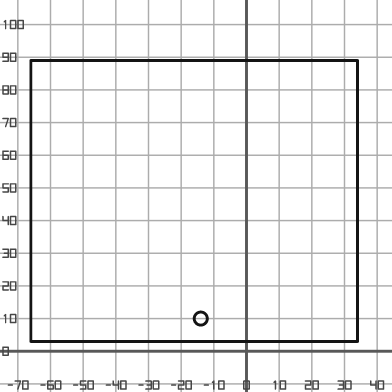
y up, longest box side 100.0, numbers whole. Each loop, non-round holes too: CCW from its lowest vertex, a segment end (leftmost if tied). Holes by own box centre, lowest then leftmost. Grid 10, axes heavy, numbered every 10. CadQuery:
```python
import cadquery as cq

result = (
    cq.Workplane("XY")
    .moveTo(-66.0, 3.0)
    .lineTo(34.0, 3.0)
    .lineTo(34.0, 89.0)
    .lineTo(-66.0, 89.0)
    .close()
    .moveTo(-14.0, 10.0)
    .circle(2.0)
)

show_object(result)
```